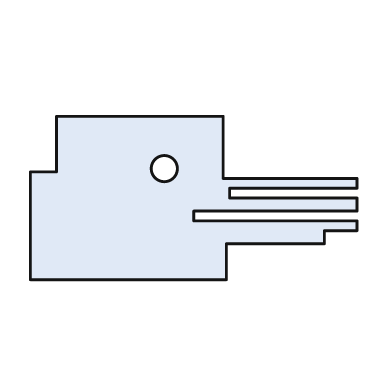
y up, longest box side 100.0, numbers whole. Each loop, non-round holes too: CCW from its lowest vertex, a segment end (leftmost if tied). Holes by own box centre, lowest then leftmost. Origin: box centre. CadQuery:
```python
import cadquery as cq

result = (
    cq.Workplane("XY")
    .moveTo(-50.0, -25.0)
    .lineTo(10.0, -25.0)
    .lineTo(10.0, -14.0)
    .lineTo(40.0, -14.0)
    .lineTo(40.0, -10.0)
    .lineTo(50.0, -10.0)
    .lineTo(50.0, -7.0)
    .lineTo(0.0, -7.0)
    .lineTo(0.0, -4.0)
    .lineTo(50.0, -4.0)
    .lineTo(50.0, 0.0)
    .lineTo(11.0, 0.0)
    .lineTo(11.0, 3.0)
    .lineTo(50.0, 3.0)
    .lineTo(50.0, 6.0)
    .lineTo(9.0, 6.0)
    .lineTo(9.0, 25.0)
    .lineTo(-42.0, 25.0)
    .lineTo(-42.0, 8.0)
    .lineTo(-50.0, 8.0)
    .close()
    .moveTo(-9.0, 9.0)
    .circle(4.0)
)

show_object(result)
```